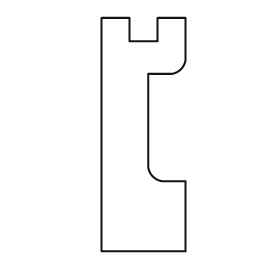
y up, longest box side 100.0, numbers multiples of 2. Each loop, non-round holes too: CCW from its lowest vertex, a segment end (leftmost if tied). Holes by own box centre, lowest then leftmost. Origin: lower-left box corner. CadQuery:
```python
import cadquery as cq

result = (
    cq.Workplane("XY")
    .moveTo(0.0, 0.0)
    .lineTo(36.0, 0.0)
    .lineTo(36.0, 30.0)
    .lineTo(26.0, 30.0)
    .threePointArc((22.0, 32.0), (20.0, 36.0))
    .lineTo(20.0, 76.0)
    .lineTo(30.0, 76.0)
    .threePointArc((34.0, 78.0), (36.0, 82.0))
    .lineTo(36.0, 100.0)
    .lineTo(24.0, 100.0)
    .lineTo(24.0, 90.0)
    .lineTo(12.0, 90.0)
    .lineTo(12.0, 100.0)
    .lineTo(0.0, 100.0)
    .close()
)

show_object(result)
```